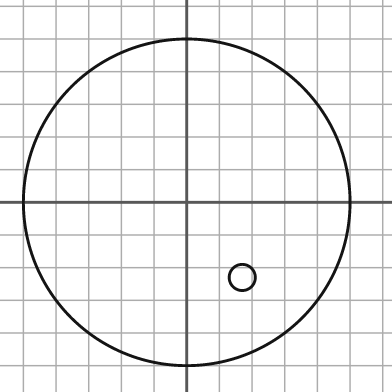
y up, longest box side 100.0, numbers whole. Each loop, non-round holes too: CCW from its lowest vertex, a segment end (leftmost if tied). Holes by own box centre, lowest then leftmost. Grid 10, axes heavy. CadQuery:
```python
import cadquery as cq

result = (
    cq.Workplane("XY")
    .moveTo(0.0, 0.0)
    .circle(50.0)
    .moveTo(17.0, -23.0)
    .circle(4.0)
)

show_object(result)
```